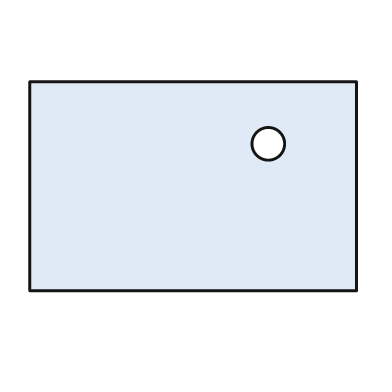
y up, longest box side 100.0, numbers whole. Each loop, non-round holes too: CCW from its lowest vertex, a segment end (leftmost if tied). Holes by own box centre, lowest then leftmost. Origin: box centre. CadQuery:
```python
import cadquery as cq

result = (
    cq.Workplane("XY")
    .moveTo(-50.0, -32.0)
    .lineTo(50.0, -32.0)
    .lineTo(50.0, 32.0)
    .lineTo(-50.0, 32.0)
    .close()
    .moveTo(23.0, 13.0)
    .circle(5.0)
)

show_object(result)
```